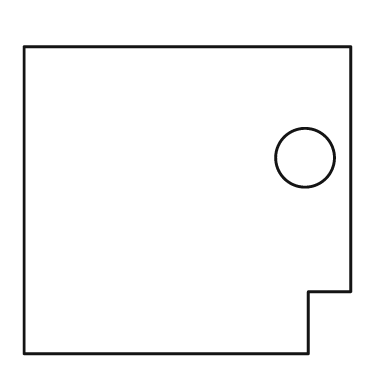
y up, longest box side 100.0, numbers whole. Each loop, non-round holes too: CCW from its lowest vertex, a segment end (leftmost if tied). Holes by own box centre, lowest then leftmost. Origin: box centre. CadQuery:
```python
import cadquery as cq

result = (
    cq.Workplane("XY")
    .moveTo(-50.0, -47.0)
    .lineTo(37.0, -47.0)
    .lineTo(37.0, -28.0)
    .lineTo(50.0, -28.0)
    .lineTo(50.0, 47.0)
    .lineTo(-50.0, 47.0)
    .close()
    .moveTo(36.0, 13.0)
    .circle(9.0)
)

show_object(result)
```